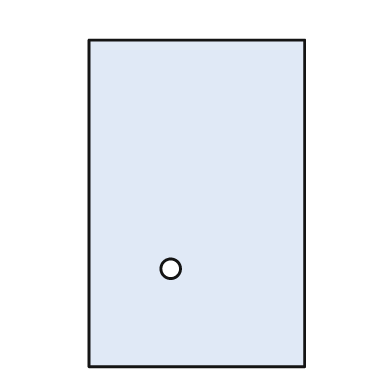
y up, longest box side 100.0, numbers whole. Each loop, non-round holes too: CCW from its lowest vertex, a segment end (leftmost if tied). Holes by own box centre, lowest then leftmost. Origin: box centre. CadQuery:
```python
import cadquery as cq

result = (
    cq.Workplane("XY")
    .moveTo(-33.0, -50.0)
    .lineTo(33.0, -50.0)
    .lineTo(33.0, 50.0)
    .lineTo(-33.0, 50.0)
    .close()
    .moveTo(-8.0, -20.0)
    .circle(3.0)
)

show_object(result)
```